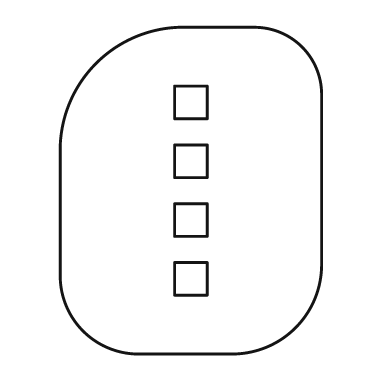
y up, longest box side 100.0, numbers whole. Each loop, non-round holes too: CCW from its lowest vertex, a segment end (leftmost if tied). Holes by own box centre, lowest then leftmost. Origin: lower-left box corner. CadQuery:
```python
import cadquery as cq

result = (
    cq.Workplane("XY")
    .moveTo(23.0, 0.0)
    .lineTo(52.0, 0.0)
    .threePointArc((72.0, 8.0), (80.0, 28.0))
    .lineTo(80.0, 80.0)
    .threePointArc((74.0, 94.0), (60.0, 100.0))
    .lineTo(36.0, 100.0)
    .threePointArc((11.0, 89.0), (0.0, 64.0))
    .lineTo(0.0, 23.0)
    .threePointArc((7.0, 7.0), (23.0, 0.0))
    .close()
    .moveTo(35.0, 18.0)
    .lineTo(45.0, 18.0)
    .lineTo(45.0, 28.0)
    .lineTo(35.0, 28.0)
    .close()
    .moveTo(35.0, 36.0)
    .lineTo(45.0, 36.0)
    .lineTo(45.0, 46.0)
    .lineTo(35.0, 46.0)
    .close()
    .moveTo(35.0, 54.0)
    .lineTo(45.0, 54.0)
    .lineTo(45.0, 64.0)
    .lineTo(35.0, 64.0)
    .close()
    .moveTo(35.0, 72.0)
    .lineTo(45.0, 72.0)
    .lineTo(45.0, 82.0)
    .lineTo(35.0, 82.0)
    .close()
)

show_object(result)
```